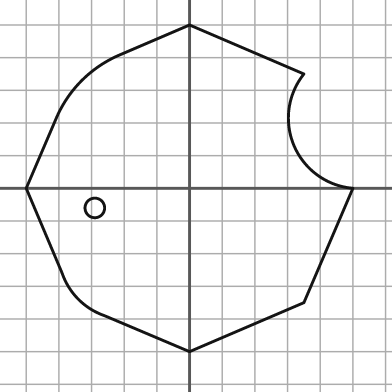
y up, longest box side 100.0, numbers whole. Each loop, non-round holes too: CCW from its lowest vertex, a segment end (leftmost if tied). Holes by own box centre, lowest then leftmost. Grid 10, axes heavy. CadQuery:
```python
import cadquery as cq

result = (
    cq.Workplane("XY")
    .moveTo(0.0, -50.0)
    .lineTo(35.0, -35.0)
    .lineTo(50.0, 0.0)
    .threePointArc((32.0, 13.0), (35.0, 35.0))
    .lineTo(0.0, 50.0)
    .lineTo(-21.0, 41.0)
    .threePointArc((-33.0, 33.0), (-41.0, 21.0))
    .lineTo(-50.0, 0.0)
    .lineTo(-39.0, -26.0)
    .threePointArc((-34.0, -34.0), (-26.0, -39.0))
    .close()
    .moveTo(-29.0, -6.0)
    .circle(3.0)
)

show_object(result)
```